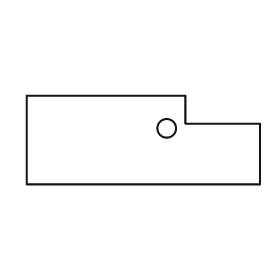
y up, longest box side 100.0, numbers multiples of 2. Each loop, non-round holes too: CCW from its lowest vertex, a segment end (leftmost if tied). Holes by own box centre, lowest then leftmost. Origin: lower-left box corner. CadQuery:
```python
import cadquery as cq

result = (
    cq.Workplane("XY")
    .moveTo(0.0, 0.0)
    .lineTo(100.0, 0.0)
    .lineTo(100.0, 26.0)
    .lineTo(68.0, 26.0)
    .lineTo(68.0, 38.0)
    .lineTo(0.0, 38.0)
    .close()
    .moveTo(60.0, 24.0)
    .circle(4.0)
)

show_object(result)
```